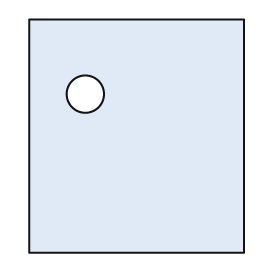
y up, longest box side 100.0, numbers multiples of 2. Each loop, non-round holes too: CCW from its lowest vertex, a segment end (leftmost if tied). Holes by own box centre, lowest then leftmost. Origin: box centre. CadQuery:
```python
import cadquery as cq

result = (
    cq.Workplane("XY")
    .moveTo(-46.0, -50.0)
    .lineTo(46.0, -50.0)
    .lineTo(46.0, 50.0)
    .lineTo(-46.0, 50.0)
    .close()
    .moveTo(-22.0, 18.0)
    .circle(8.0)
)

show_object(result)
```